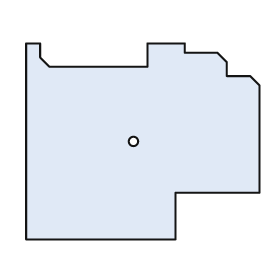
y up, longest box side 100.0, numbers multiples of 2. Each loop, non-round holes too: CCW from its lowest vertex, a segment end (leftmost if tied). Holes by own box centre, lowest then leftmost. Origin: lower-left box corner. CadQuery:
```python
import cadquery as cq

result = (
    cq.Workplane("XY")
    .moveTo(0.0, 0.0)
    .lineTo(64.0, 0.0)
    .lineTo(64.0, 20.0)
    .lineTo(100.0, 20.0)
    .lineTo(100.0, 66.0)
    .lineTo(96.0, 70.0)
    .lineTo(86.0, 70.0)
    .lineTo(86.0, 76.0)
    .lineTo(82.0, 80.0)
    .lineTo(68.0, 80.0)
    .lineTo(68.0, 84.0)
    .lineTo(52.0, 84.0)
    .lineTo(52.0, 74.0)
    .lineTo(10.0, 74.0)
    .lineTo(6.0, 78.0)
    .lineTo(6.0, 84.0)
    .lineTo(0.0, 84.0)
    .close()
    .moveTo(46.0, 42.0)
    .circle(2.0)
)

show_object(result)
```